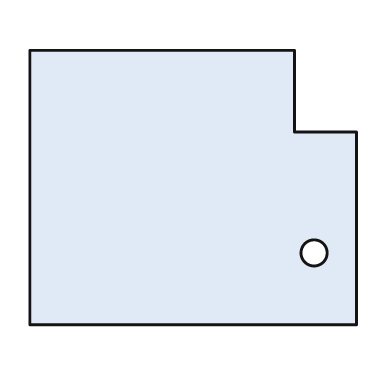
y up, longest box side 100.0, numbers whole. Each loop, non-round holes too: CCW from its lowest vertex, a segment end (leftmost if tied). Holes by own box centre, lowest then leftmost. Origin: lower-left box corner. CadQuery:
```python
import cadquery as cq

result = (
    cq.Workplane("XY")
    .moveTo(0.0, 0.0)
    .lineTo(100.0, 0.0)
    .lineTo(100.0, 59.0)
    .lineTo(81.0, 59.0)
    .lineTo(81.0, 84.0)
    .lineTo(0.0, 84.0)
    .close()
    .moveTo(87.0, 22.0)
    .circle(4.0)
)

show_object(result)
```